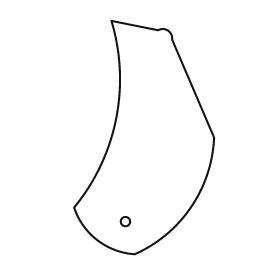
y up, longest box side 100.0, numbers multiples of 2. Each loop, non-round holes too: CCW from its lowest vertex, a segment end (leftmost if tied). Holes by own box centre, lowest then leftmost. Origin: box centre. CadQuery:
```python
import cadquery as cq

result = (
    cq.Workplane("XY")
    .moveTo(-4.0, -50.0)
    .threePointArc((20.0, -30.0), (30.0, 0.0))
    .lineTo(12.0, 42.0)
    .threePointArc((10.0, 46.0), (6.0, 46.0))
    .lineTo(-14.0, 50.0)
    .threePointArc((-12.0, 8.0), (-30.0, -30.0))
    .threePointArc((-20.0, -44.0), (-4.0, -50.0))
    .close()
    .moveTo(-8.0, -36.0)
    .circle(2.0)
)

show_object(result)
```